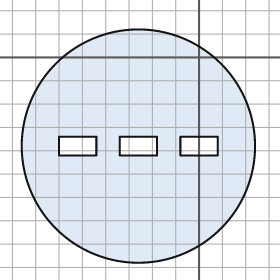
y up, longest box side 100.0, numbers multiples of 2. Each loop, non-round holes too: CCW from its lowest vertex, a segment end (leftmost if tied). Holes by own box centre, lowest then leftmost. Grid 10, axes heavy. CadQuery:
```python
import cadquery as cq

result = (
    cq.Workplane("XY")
    .moveTo(-26.0, -38.0)
    .circle(50.0)
    .moveTo(-60.0, -42.0)
    .lineTo(-44.0, -42.0)
    .lineTo(-44.0, -34.0)
    .lineTo(-60.0, -34.0)
    .close()
    .moveTo(-34.0, -42.0)
    .lineTo(-18.0, -42.0)
    .lineTo(-18.0, -34.0)
    .lineTo(-34.0, -34.0)
    .close()
    .moveTo(-8.0, -42.0)
    .lineTo(8.0, -42.0)
    .lineTo(8.0, -34.0)
    .lineTo(-8.0, -34.0)
    .close()
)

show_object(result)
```